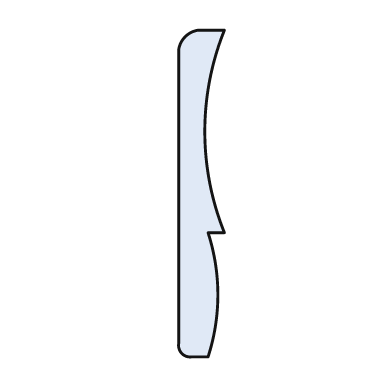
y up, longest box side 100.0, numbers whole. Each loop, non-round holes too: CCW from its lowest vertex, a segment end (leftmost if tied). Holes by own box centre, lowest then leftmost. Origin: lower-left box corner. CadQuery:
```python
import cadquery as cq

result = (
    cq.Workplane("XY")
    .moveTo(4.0, 0.0)
    .lineTo(9.0, 0.0)
    .threePointArc((12.0, 19.0), (9.0, 38.0))
    .lineTo(14.0, 38.0)
    .threePointArc((8.0, 69.0), (14.0, 100.0))
    .lineTo(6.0, 100.0)
    .threePointArc((2.0, 98.0), (0.0, 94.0))
    .lineTo(0.0, 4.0)
    .threePointArc((1.0, 1.0), (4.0, 0.0))
    .close()
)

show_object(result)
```